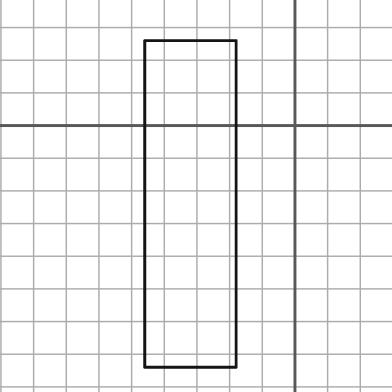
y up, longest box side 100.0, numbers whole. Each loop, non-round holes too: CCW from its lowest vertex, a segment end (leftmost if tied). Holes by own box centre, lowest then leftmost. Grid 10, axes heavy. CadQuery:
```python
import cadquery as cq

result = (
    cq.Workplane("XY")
    .moveTo(-46.0, -74.0)
    .lineTo(-18.0, -74.0)
    .lineTo(-18.0, 26.0)
    .lineTo(-46.0, 26.0)
    .close()
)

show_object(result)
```